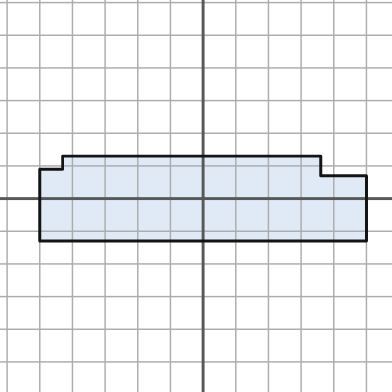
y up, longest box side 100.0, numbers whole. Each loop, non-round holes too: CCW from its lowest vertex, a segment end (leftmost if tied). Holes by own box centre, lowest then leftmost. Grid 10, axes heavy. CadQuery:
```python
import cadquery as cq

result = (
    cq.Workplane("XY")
    .moveTo(-50.0, -13.0)
    .lineTo(50.0, -13.0)
    .lineTo(50.0, 7.0)
    .lineTo(36.0, 7.0)
    .lineTo(36.0, 13.0)
    .lineTo(-43.0, 13.0)
    .lineTo(-43.0, 9.0)
    .lineTo(-50.0, 9.0)
    .close()
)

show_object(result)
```